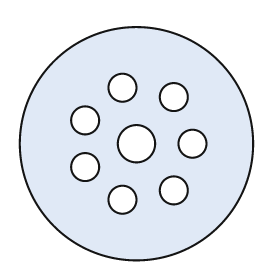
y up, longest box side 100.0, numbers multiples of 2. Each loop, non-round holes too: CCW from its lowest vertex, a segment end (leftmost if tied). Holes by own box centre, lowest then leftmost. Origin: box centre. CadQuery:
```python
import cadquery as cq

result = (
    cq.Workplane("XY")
    .moveTo(0.0, 0.0)
    .circle(50.0)
    .moveTo(-6.0, -24.0)
    .circle(6.0)
    .moveTo(16.0, -20.0)
    .circle(6.0)
    .moveTo(-22.0, -10.0)
    .circle(6.0)
    .moveTo(0.0, 0.0)
    .circle(8.0)
    .moveTo(24.0, 0.0)
    .circle(6.0)
    .moveTo(-22.0, 10.0)
    .circle(6.0)
    .moveTo(16.0, 20.0)
    .circle(6.0)
    .moveTo(-6.0, 24.0)
    .circle(6.0)
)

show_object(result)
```